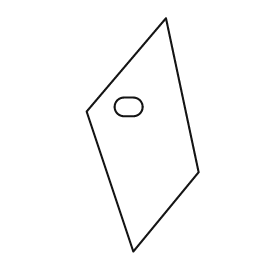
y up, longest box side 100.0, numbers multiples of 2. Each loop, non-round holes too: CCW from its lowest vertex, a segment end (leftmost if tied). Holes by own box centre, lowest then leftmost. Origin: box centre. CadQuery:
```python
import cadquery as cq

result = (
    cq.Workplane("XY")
    .moveTo(-4.0, -50.0)
    .lineTo(24.0, -16.0)
    .lineTo(10.0, 50.0)
    .lineTo(-24.0, 10.0)
    .close()
    .moveTo(-8.0, 8.0)
    .lineTo(-4.0, 8.0)
    .threePointArc((0.0, 12.0), (-4.0, 16.0))
    .lineTo(-8.0, 16.0)
    .threePointArc((-12.0, 12.0), (-8.0, 8.0))
    .close()
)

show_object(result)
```